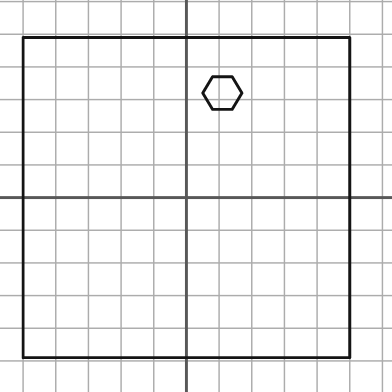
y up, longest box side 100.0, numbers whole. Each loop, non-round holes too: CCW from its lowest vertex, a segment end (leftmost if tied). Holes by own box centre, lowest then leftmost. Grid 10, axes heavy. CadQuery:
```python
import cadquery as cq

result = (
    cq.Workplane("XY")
    .moveTo(-50.0, -49.0)
    .lineTo(50.0, -49.0)
    .lineTo(50.0, 49.0)
    .lineTo(-50.0, 49.0)
    .close()
    .moveTo(8.0, 27.0)
    .lineTo(14.0, 27.0)
    .lineTo(17.0, 32.0)
    .lineTo(14.0, 37.0)
    .lineTo(8.0, 37.0)
    .lineTo(5.0, 32.0)
    .close()
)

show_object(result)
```